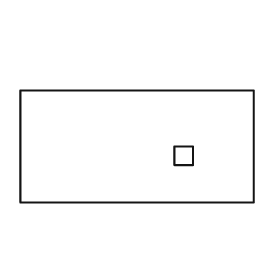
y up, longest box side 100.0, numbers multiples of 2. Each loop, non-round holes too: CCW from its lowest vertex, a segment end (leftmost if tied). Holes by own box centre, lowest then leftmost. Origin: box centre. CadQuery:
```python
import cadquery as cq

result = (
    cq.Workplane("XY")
    .moveTo(-50.0, -24.0)
    .lineTo(50.0, -24.0)
    .lineTo(50.0, 24.0)
    .lineTo(-50.0, 24.0)
    .close()
    .moveTo(16.0, -8.0)
    .lineTo(24.0, -8.0)
    .lineTo(24.0, 0.0)
    .lineTo(16.0, 0.0)
    .close()
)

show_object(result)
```